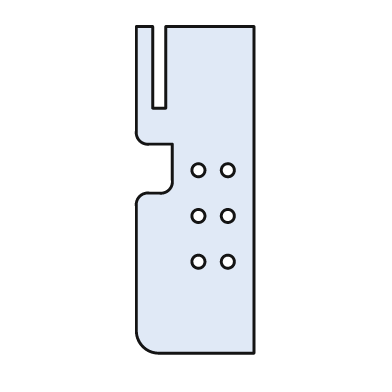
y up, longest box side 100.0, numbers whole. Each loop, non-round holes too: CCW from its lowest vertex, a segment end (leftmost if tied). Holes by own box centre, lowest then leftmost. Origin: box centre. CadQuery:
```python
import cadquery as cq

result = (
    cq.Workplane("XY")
    .moveTo(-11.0, -50.0)
    .lineTo(18.0, -50.0)
    .lineTo(18.0, 50.0)
    .lineTo(-9.0, 50.0)
    .lineTo(-9.0, 25.0)
    .lineTo(-13.0, 25.0)
    .lineTo(-13.0, 50.0)
    .lineTo(-18.0, 50.0)
    .lineTo(-18.0, 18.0)
    .threePointArc((-17.0, 15.0), (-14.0, 14.0))
    .lineTo(-7.0, 14.0)
    .lineTo(-7.0, 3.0)
    .threePointArc((-8.0, 0.0), (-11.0, -1.0))
    .lineTo(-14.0, -1.0)
    .threePointArc((-17.0, -2.0), (-18.0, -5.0))
    .lineTo(-18.0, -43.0)
    .threePointArc((-16.0, -48.0), (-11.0, -50.0))
    .close()
    .moveTo(1.0, -22.0)
    .circle(2.0)
    .moveTo(10.0, -22.0)
    .circle(2.0)
    .moveTo(1.0, -8.0)
    .circle(2.0)
    .moveTo(10.0, -8.0)
    .circle(2.0)
    .moveTo(1.0, 6.0)
    .circle(2.0)
    .moveTo(10.0, 6.0)
    .circle(2.0)
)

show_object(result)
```